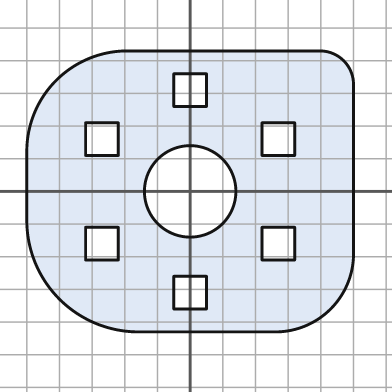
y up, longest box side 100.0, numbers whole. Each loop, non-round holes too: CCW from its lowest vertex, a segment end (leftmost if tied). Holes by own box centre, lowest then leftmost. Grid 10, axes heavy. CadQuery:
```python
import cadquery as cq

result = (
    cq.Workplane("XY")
    .moveTo(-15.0, -43.0)
    .lineTo(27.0, -43.0)
    .threePointArc((43.0, -36.0), (50.0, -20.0))
    .lineTo(50.0, 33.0)
    .threePointArc((47.0, 40.0), (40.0, 43.0))
    .lineTo(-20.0, 43.0)
    .threePointArc((-41.0, 34.0), (-50.0, 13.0))
    .lineTo(-50.0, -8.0)
    .threePointArc((-40.0, -33.0), (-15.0, -43.0))
    .close()
    .moveTo(-5.0, -36.0)
    .lineTo(5.0, -36.0)
    .lineTo(5.0, -26.0)
    .lineTo(-5.0, -26.0)
    .close()
    .moveTo(-32.0, -21.0)
    .lineTo(-22.0, -21.0)
    .lineTo(-22.0, -11.0)
    .lineTo(-32.0, -11.0)
    .close()
    .moveTo(22.0, -21.0)
    .lineTo(32.0, -21.0)
    .lineTo(32.0, -11.0)
    .lineTo(22.0, -11.0)
    .close()
    .moveTo(0.0, 0.0)
    .circle(14.0)
    .moveTo(-32.0, 11.0)
    .lineTo(-22.0, 11.0)
    .lineTo(-22.0, 21.0)
    .lineTo(-32.0, 21.0)
    .close()
    .moveTo(22.0, 11.0)
    .lineTo(32.0, 11.0)
    .lineTo(32.0, 21.0)
    .lineTo(22.0, 21.0)
    .close()
    .moveTo(-5.0, 26.0)
    .lineTo(5.0, 26.0)
    .lineTo(5.0, 36.0)
    .lineTo(-5.0, 36.0)
    .close()
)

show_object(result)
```